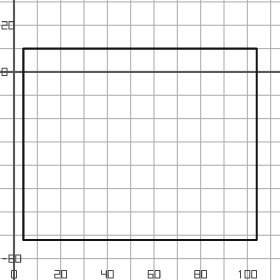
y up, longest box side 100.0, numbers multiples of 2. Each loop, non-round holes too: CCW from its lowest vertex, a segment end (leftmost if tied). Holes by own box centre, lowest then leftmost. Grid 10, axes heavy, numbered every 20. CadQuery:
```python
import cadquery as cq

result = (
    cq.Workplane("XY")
    .moveTo(4.0, -72.0)
    .lineTo(104.0, -72.0)
    .lineTo(104.0, 10.0)
    .lineTo(4.0, 10.0)
    .close()
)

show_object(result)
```